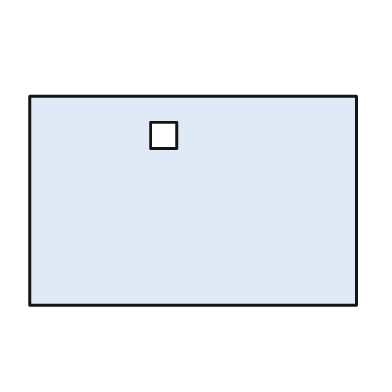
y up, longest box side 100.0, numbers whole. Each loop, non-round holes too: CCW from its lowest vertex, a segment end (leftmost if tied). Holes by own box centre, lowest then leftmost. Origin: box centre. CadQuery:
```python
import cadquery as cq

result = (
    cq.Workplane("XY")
    .moveTo(-50.0, -32.0)
    .lineTo(50.0, -32.0)
    .lineTo(50.0, 32.0)
    .lineTo(-50.0, 32.0)
    .close()
    .moveTo(-13.0, 16.0)
    .lineTo(-5.0, 16.0)
    .lineTo(-5.0, 24.0)
    .lineTo(-13.0, 24.0)
    .close()
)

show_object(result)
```